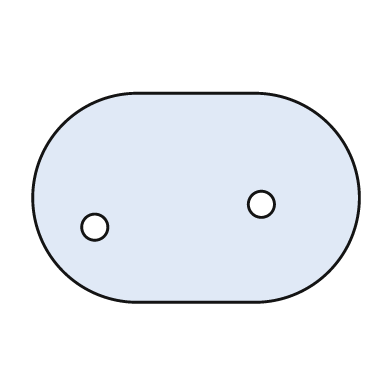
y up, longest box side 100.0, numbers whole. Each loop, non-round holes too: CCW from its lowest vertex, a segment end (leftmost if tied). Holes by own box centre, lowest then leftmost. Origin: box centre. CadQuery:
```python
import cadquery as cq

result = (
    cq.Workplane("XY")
    .moveTo(-18.0, -32.0)
    .lineTo(18.0, -32.0)
    .threePointArc((50.0, 0.0), (18.0, 32.0))
    .lineTo(-18.0, 32.0)
    .threePointArc((-50.0, 0.0), (-18.0, -32.0))
    .close()
    .moveTo(-31.0, -9.0)
    .circle(4.0)
    .moveTo(20.0, -2.0)
    .circle(4.0)
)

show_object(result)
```